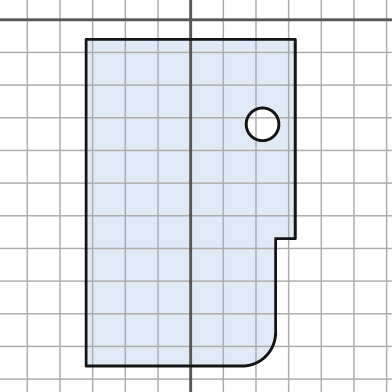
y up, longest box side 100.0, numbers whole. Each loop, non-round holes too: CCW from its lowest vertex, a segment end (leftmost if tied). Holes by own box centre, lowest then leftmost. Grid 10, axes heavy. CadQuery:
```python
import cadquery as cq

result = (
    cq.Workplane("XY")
    .moveTo(-32.0, -106.0)
    .lineTo(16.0, -106.0)
    .threePointArc((23.0, -103.0), (26.0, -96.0))
    .lineTo(26.0, -67.0)
    .lineTo(32.0, -67.0)
    .lineTo(32.0, -6.0)
    .lineTo(-32.0, -6.0)
    .close()
    .moveTo(22.0, -32.0)
    .circle(5.0)
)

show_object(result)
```